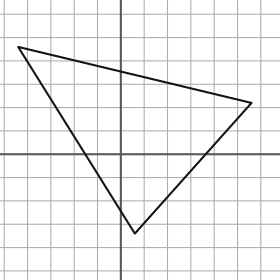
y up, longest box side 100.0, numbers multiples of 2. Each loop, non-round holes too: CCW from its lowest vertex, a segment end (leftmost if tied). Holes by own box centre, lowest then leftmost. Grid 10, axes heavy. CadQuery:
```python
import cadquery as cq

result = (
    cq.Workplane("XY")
    .moveTo(6.0, -34.0)
    .lineTo(56.0, 22.0)
    .lineTo(-44.0, 46.0)
    .close()
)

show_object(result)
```